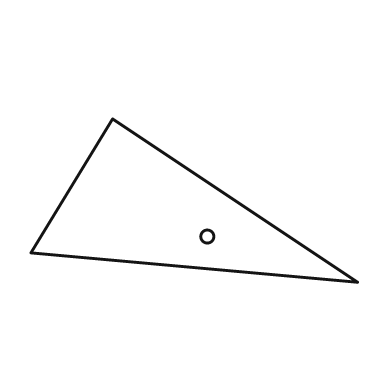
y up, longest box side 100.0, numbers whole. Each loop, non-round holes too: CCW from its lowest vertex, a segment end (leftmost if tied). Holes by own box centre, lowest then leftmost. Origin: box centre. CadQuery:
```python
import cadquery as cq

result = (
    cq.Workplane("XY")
    .moveTo(50.0, -25.0)
    .lineTo(-25.0, 25.0)
    .lineTo(-50.0, -16.0)
    .close()
    .moveTo(4.0, -11.0)
    .circle(2.0)
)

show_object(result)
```